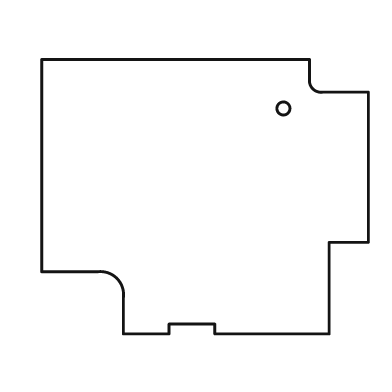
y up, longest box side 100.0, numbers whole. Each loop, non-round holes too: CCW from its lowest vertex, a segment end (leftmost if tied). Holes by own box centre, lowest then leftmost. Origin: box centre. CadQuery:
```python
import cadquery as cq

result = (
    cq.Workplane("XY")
    .moveTo(-25.0, -42.0)
    .lineTo(-11.0, -42.0)
    .lineTo(-11.0, -39.0)
    .lineTo(3.0, -39.0)
    .lineTo(3.0, -42.0)
    .lineTo(38.0, -42.0)
    .lineTo(38.0, -14.0)
    .lineTo(50.0, -14.0)
    .lineTo(50.0, 32.0)
    .lineTo(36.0, 32.0)
    .threePointArc((33.0, 33.0), (32.0, 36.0))
    .lineTo(32.0, 42.0)
    .lineTo(-50.0, 42.0)
    .lineTo(-50.0, -23.0)
    .lineTo(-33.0, -23.0)
    .threePointArc((-27.0, -25.0), (-25.0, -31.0))
    .close()
    .moveTo(24.0, 27.0)
    .circle(2.0)
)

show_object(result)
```